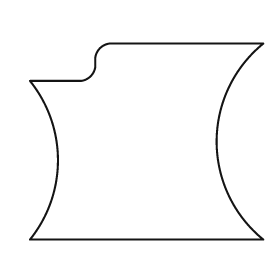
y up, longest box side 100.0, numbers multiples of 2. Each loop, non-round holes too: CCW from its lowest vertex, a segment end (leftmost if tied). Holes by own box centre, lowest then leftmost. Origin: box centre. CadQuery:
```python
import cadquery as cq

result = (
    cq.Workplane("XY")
    .moveTo(-50.0, -42.0)
    .lineTo(50.0, -42.0)
    .threePointArc((30.0, 0.0), (50.0, 42.0))
    .lineTo(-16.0, 42.0)
    .threePointArc((-20.0, 40.0), (-22.0, 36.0))
    .lineTo(-22.0, 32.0)
    .threePointArc((-24.0, 28.0), (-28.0, 26.0))
    .lineTo(-50.0, 26.0)
    .threePointArc((-38.0, -8.0), (-50.0, -42.0))
    .close()
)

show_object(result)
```